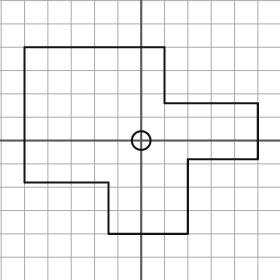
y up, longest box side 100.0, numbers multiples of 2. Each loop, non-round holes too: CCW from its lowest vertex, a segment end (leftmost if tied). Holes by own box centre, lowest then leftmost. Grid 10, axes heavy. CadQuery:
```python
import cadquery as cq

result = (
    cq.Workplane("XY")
    .moveTo(-14.0, -40.0)
    .lineTo(20.0, -40.0)
    .lineTo(20.0, -8.0)
    .lineTo(50.0, -8.0)
    .lineTo(50.0, 16.0)
    .lineTo(10.0, 16.0)
    .lineTo(10.0, 40.0)
    .lineTo(-50.0, 40.0)
    .lineTo(-50.0, -18.0)
    .lineTo(-14.0, -18.0)
    .close()
    .moveTo(0.0, 0.0)
    .circle(4.0)
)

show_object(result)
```